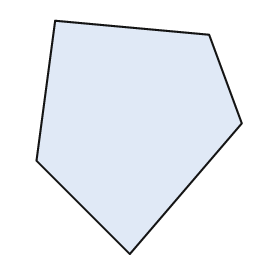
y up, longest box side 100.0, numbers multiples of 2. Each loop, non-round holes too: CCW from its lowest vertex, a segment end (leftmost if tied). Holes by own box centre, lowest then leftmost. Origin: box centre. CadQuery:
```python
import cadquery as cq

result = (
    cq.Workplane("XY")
    .moveTo(-4.0, -50.0)
    .lineTo(44.0, 6.0)
    .lineTo(30.0, 44.0)
    .lineTo(-36.0, 50.0)
    .lineTo(-44.0, -10.0)
    .close()
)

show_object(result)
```